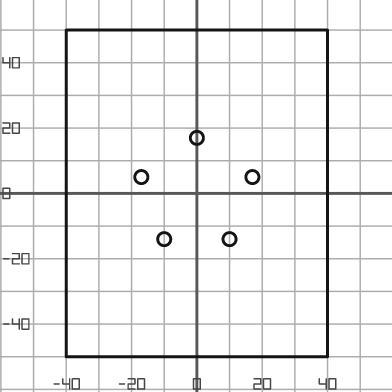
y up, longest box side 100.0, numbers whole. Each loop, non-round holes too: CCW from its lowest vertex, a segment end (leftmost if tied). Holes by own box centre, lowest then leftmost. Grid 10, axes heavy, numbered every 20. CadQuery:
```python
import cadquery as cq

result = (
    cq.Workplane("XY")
    .moveTo(-40.0, -50.0)
    .lineTo(40.0, -50.0)
    .lineTo(40.0, 50.0)
    .lineTo(-40.0, 50.0)
    .close()
    .moveTo(-10.0, -14.0)
    .circle(2.0)
    .moveTo(10.0, -14.0)
    .circle(2.0)
    .moveTo(-17.0, 5.0)
    .circle(2.0)
    .moveTo(17.0, 5.0)
    .circle(2.0)
    .moveTo(0.0, 17.0)
    .circle(2.0)
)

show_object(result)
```